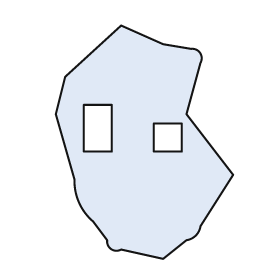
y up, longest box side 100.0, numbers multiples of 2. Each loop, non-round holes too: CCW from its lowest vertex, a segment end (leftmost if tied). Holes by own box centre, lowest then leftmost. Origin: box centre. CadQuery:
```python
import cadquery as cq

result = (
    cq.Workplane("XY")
    .moveTo(8.0, -50.0)
    .lineTo(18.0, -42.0)
    .threePointArc((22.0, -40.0), (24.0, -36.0))
    .lineTo(38.0, -14.0)
    .lineTo(18.0, 12.0)
    .lineTo(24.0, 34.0)
    .threePointArc((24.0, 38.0), (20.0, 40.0))
    .lineTo(8.0, 42.0)
    .lineTo(-10.0, 50.0)
    .lineTo(-34.0, 28.0)
    .lineTo(-38.0, 12.0)
    .lineTo(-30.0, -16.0)
    .threePointArc((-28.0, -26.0), (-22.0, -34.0))
    .lineTo(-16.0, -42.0)
    .threePointArc((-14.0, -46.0), (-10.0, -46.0))
    .close()
    .moveTo(4.0, -4.0)
    .lineTo(16.0, -4.0)
    .lineTo(16.0, 8.0)
    .lineTo(4.0, 8.0)
    .close()
    .moveTo(-26.0, -4.0)
    .lineTo(-14.0, -4.0)
    .lineTo(-14.0, 16.0)
    .lineTo(-26.0, 16.0)
    .close()
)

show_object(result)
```